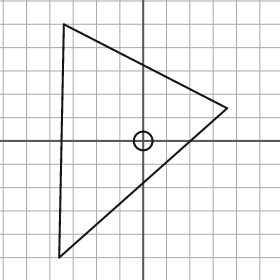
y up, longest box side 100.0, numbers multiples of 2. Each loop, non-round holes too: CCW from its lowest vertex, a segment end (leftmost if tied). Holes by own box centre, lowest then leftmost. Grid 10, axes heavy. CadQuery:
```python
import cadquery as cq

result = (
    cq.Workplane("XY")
    .moveTo(-36.0, -50.0)
    .lineTo(36.0, 14.0)
    .lineTo(-34.0, 50.0)
    .close()
    .moveTo(0.0, 0.0)
    .circle(4.0)
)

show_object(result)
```